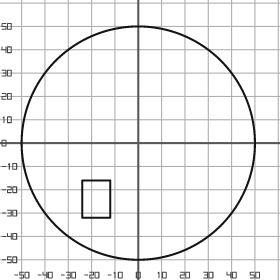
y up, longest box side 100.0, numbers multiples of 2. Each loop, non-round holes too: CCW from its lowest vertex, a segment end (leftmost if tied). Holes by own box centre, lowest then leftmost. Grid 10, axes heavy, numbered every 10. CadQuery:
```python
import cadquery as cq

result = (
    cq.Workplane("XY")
    .moveTo(0.0, 0.0)
    .circle(50.0)
    .moveTo(-24.0, -32.0)
    .lineTo(-12.0, -32.0)
    .lineTo(-12.0, -16.0)
    .lineTo(-24.0, -16.0)
    .close()
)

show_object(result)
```